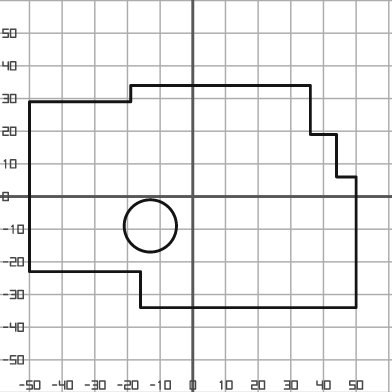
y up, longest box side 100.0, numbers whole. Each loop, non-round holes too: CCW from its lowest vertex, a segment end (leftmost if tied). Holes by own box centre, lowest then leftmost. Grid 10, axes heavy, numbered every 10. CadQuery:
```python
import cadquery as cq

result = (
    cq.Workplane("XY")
    .moveTo(-16.0, -34.0)
    .lineTo(50.0, -34.0)
    .lineTo(50.0, 6.0)
    .lineTo(44.0, 6.0)
    .lineTo(44.0, 19.0)
    .lineTo(36.0, 19.0)
    .lineTo(36.0, 34.0)
    .lineTo(-19.0, 34.0)
    .lineTo(-19.0, 29.0)
    .lineTo(-50.0, 29.0)
    .lineTo(-50.0, -23.0)
    .lineTo(-16.0, -23.0)
    .close()
    .moveTo(-13.0, -9.0)
    .circle(8.0)
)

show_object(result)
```